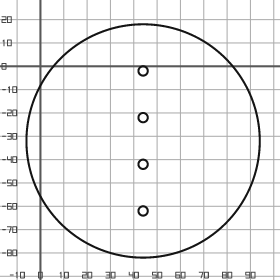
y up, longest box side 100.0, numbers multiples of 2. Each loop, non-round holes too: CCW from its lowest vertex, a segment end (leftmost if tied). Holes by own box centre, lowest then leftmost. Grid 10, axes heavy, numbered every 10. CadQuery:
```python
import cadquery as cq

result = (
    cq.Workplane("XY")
    .moveTo(44.0, -32.0)
    .circle(50.0)
    .moveTo(44.0, -62.0)
    .circle(2.0)
    .moveTo(44.0, -42.0)
    .circle(2.0)
    .moveTo(44.0, -22.0)
    .circle(2.0)
    .moveTo(44.0, -2.0)
    .circle(2.0)
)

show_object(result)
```